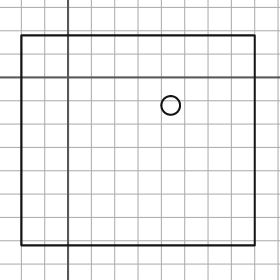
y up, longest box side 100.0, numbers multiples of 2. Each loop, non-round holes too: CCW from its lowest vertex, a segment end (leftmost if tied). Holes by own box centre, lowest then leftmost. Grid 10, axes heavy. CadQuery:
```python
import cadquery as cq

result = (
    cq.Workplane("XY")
    .moveTo(-20.0, -72.0)
    .lineTo(80.0, -72.0)
    .lineTo(80.0, 18.0)
    .lineTo(-20.0, 18.0)
    .close()
    .moveTo(44.0, -12.0)
    .circle(4.0)
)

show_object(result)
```